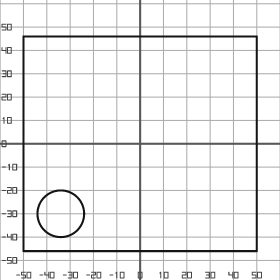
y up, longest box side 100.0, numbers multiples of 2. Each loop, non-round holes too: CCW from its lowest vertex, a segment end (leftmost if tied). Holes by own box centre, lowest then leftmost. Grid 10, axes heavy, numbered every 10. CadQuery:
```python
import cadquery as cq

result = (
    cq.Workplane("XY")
    .moveTo(-50.0, -46.0)
    .lineTo(50.0, -46.0)
    .lineTo(50.0, 46.0)
    .lineTo(-50.0, 46.0)
    .close()
    .moveTo(-34.0, -30.0)
    .circle(10.0)
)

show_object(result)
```